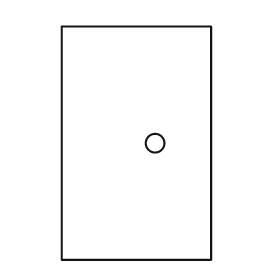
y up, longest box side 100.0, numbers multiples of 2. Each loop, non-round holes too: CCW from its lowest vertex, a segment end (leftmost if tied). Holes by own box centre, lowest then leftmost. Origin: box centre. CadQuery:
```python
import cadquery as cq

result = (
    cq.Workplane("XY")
    .moveTo(-32.0, -50.0)
    .lineTo(32.0, -50.0)
    .lineTo(32.0, 50.0)
    .lineTo(-32.0, 50.0)
    .close()
    .moveTo(8.0, 0.0)
    .circle(4.0)
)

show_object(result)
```